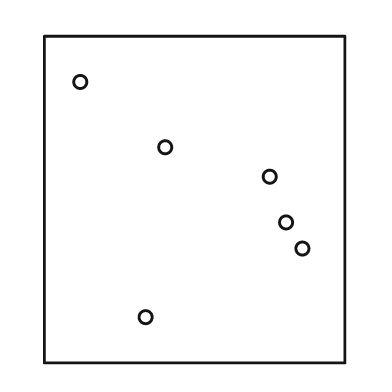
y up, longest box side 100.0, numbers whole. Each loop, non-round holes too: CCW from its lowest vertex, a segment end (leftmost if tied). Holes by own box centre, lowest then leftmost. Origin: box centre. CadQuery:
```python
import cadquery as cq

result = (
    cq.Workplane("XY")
    .moveTo(-46.0, -50.0)
    .lineTo(46.0, -50.0)
    .lineTo(46.0, 50.0)
    .lineTo(-46.0, 50.0)
    .close()
    .moveTo(-15.0, -36.0)
    .circle(2.0)
    .moveTo(33.0, -15.0)
    .circle(2.0)
    .moveTo(28.0, -7.0)
    .circle(2.0)
    .moveTo(23.0, 7.0)
    .circle(2.0)
    .moveTo(-9.0, 16.0)
    .circle(2.0)
    .moveTo(-35.0, 36.0)
    .circle(2.0)
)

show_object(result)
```